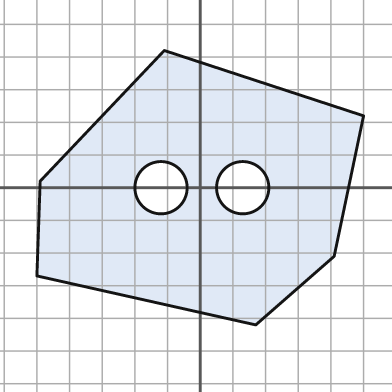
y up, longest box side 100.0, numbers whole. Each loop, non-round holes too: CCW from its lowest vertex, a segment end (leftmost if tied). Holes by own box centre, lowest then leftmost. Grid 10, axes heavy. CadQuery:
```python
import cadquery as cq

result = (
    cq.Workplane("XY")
    .moveTo(17.0, -42.0)
    .lineTo(41.0, -21.0)
    .lineTo(50.0, 22.0)
    .lineTo(-11.0, 42.0)
    .lineTo(-49.0, 2.0)
    .lineTo(-50.0, -27.0)
    .close()
    .moveTo(-12.0, 0.0)
    .circle(8.0)
    .moveTo(13.0, 0.0)
    .circle(8.0)
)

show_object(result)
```